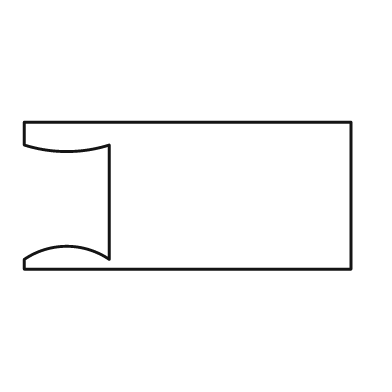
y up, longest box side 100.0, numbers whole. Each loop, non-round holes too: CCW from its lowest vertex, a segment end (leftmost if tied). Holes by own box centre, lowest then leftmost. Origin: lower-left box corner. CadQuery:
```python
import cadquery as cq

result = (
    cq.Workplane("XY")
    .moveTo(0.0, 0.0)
    .lineTo(100.0, 0.0)
    .lineTo(100.0, 45.0)
    .lineTo(0.0, 45.0)
    .lineTo(0.0, 38.0)
    .threePointArc((13.0, 36.0), (26.0, 38.0))
    .lineTo(26.0, 3.0)
    .threePointArc((13.0, 7.0), (0.0, 3.0))
    .close()
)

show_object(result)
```